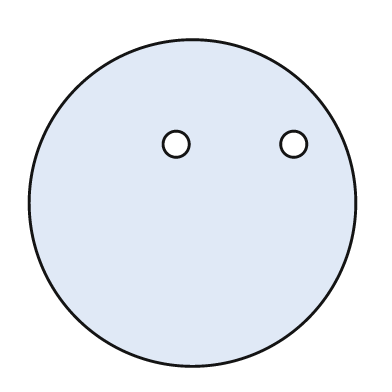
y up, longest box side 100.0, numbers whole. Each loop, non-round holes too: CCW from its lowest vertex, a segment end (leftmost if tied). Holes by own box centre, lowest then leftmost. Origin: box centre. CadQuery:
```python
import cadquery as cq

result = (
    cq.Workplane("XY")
    .moveTo(0.0, 0.0)
    .circle(50.0)
    .moveTo(-5.0, 18.0)
    .circle(4.0)
    .moveTo(31.0, 18.0)
    .circle(4.0)
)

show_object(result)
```